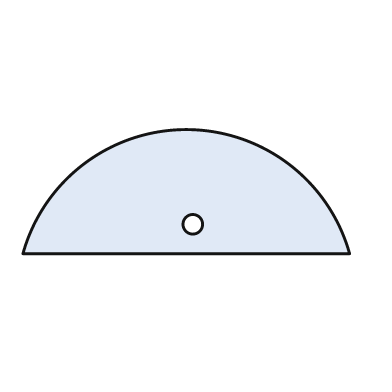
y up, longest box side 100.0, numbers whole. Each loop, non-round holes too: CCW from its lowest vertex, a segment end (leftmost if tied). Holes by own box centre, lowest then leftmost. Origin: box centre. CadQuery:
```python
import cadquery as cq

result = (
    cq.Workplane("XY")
    .moveTo(-50.0, -19.0)
    .lineTo(50.0, -19.0)
    .threePointArc((0.0, 19.0), (-50.0, -19.0))
    .close()
    .moveTo(2.0, -10.0)
    .circle(3.0)
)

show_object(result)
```